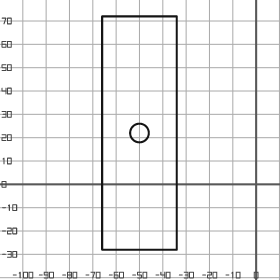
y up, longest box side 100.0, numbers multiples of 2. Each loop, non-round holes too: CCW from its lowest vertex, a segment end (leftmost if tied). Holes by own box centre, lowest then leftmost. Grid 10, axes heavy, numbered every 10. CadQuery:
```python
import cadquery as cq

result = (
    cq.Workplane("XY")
    .moveTo(-66.0, -28.0)
    .lineTo(-34.0, -28.0)
    .lineTo(-34.0, 72.0)
    .lineTo(-66.0, 72.0)
    .close()
    .moveTo(-50.0, 22.0)
    .circle(4.0)
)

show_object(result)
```